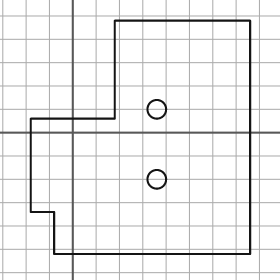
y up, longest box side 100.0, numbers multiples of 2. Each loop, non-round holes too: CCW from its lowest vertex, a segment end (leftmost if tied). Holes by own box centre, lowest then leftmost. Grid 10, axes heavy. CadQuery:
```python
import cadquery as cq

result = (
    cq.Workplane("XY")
    .moveTo(-8.0, -52.0)
    .lineTo(76.0, -52.0)
    .lineTo(76.0, 48.0)
    .lineTo(18.0, 48.0)
    .lineTo(18.0, 6.0)
    .lineTo(-18.0, 6.0)
    .lineTo(-18.0, -34.0)
    .lineTo(-8.0, -34.0)
    .close()
    .moveTo(36.0, -20.0)
    .circle(4.0)
    .moveTo(36.0, 10.0)
    .circle(4.0)
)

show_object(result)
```